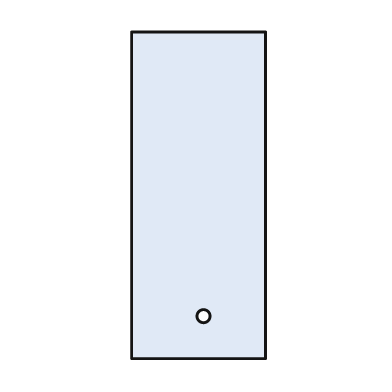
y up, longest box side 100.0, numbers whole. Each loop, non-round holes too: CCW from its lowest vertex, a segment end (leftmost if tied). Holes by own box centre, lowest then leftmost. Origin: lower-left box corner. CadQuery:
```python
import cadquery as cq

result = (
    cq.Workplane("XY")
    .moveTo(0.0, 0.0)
    .lineTo(41.0, 0.0)
    .lineTo(41.0, 100.0)
    .lineTo(0.0, 100.0)
    .close()
    .moveTo(22.0, 13.0)
    .circle(2.0)
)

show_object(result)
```